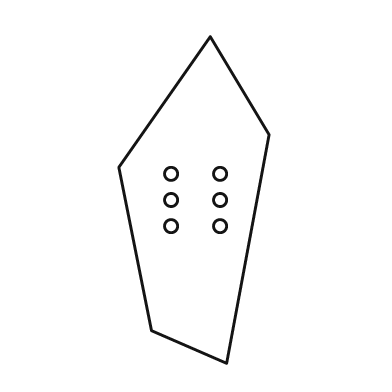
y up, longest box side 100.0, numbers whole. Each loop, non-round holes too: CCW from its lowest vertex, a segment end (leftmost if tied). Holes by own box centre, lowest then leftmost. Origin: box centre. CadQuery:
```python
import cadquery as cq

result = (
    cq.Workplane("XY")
    .moveTo(10.0, -50.0)
    .lineTo(23.0, 20.0)
    .lineTo(5.0, 50.0)
    .lineTo(-23.0, 10.0)
    .lineTo(-13.0, -40.0)
    .close()
    .moveTo(-7.0, -8.0)
    .circle(2.0)
    .moveTo(8.0, -8.0)
    .circle(2.0)
    .moveTo(-7.0, 0.0)
    .circle(2.0)
    .moveTo(8.0, 0.0)
    .circle(2.0)
    .moveTo(-7.0, 8.0)
    .circle(2.0)
    .moveTo(8.0, 8.0)
    .circle(2.0)
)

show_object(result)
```